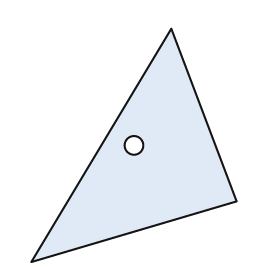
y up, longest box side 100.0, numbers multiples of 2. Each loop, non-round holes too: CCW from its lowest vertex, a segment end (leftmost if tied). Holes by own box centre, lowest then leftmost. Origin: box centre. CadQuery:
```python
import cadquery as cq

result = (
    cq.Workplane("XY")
    .moveTo(-44.0, -50.0)
    .lineTo(44.0, -24.0)
    .lineTo(16.0, 50.0)
    .close()
    .moveTo(0.0, 0.0)
    .circle(4.0)
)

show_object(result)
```